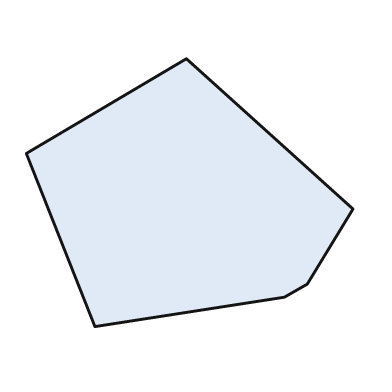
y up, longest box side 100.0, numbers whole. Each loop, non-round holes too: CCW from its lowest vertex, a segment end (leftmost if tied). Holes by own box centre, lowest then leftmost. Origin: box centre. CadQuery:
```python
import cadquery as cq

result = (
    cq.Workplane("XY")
    .moveTo(-29.0, -41.0)
    .lineTo(29.0, -32.0)
    .lineTo(36.0, -28.0)
    .lineTo(50.0, -5.0)
    .lineTo(-1.0, 41.0)
    .lineTo(-50.0, 12.0)
    .close()
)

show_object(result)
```